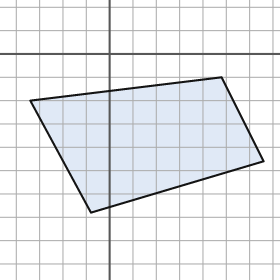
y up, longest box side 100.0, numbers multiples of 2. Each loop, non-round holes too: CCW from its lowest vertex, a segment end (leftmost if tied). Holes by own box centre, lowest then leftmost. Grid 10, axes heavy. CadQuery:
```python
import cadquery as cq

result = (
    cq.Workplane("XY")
    .moveTo(-8.0, -68.0)
    .lineTo(66.0, -46.0)
    .lineTo(48.0, -10.0)
    .lineTo(-34.0, -20.0)
    .close()
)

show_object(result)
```